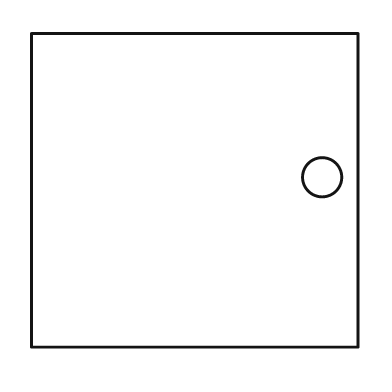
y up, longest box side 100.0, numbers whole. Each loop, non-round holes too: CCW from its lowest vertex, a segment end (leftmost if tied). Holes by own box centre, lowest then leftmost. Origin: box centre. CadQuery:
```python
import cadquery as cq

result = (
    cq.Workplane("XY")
    .moveTo(-50.0, -48.0)
    .lineTo(50.0, -48.0)
    .lineTo(50.0, 48.0)
    .lineTo(-50.0, 48.0)
    .close()
    .moveTo(39.0, 4.0)
    .circle(6.0)
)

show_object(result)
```